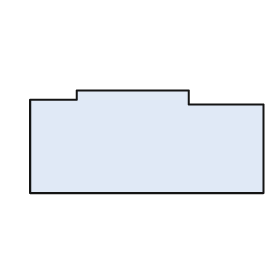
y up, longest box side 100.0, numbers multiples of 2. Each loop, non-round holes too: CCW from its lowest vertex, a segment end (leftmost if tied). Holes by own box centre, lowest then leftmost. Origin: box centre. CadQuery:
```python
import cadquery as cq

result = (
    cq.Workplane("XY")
    .moveTo(-50.0, -22.0)
    .lineTo(50.0, -22.0)
    .lineTo(50.0, 16.0)
    .lineTo(18.0, 16.0)
    .lineTo(18.0, 22.0)
    .lineTo(-30.0, 22.0)
    .lineTo(-30.0, 18.0)
    .lineTo(-50.0, 18.0)
    .close()
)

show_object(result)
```